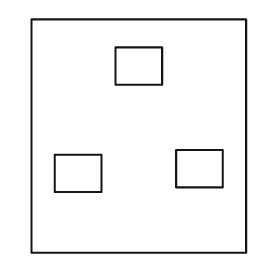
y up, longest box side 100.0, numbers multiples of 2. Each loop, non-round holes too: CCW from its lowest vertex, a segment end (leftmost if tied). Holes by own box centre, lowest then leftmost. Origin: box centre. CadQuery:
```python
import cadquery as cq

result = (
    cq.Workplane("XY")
    .moveTo(-46.0, -50.0)
    .lineTo(46.0, -50.0)
    .lineTo(46.0, 50.0)
    .lineTo(-46.0, 50.0)
    .close()
    .moveTo(-36.0, -24.0)
    .lineTo(-16.0, -24.0)
    .lineTo(-16.0, -8.0)
    .lineTo(-36.0, -8.0)
    .close()
    .moveTo(16.0, -22.0)
    .lineTo(36.0, -22.0)
    .lineTo(36.0, -6.0)
    .lineTo(16.0, -6.0)
    .close()
    .moveTo(-10.0, 22.0)
    .lineTo(10.0, 22.0)
    .lineTo(10.0, 38.0)
    .lineTo(-10.0, 38.0)
    .close()
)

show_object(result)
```